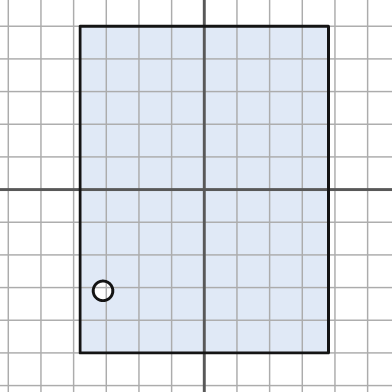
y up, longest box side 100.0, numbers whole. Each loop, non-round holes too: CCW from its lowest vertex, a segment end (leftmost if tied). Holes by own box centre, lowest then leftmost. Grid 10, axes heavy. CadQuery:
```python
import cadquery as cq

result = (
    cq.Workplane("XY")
    .moveTo(-38.0, -50.0)
    .lineTo(38.0, -50.0)
    .lineTo(38.0, 50.0)
    .lineTo(-38.0, 50.0)
    .close()
    .moveTo(-31.0, -31.0)
    .circle(3.0)
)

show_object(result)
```